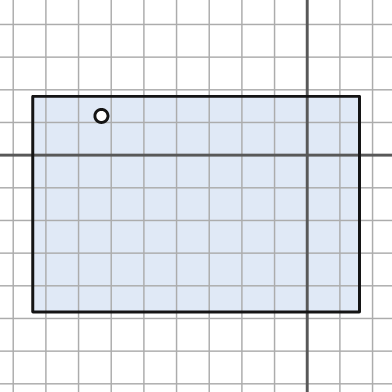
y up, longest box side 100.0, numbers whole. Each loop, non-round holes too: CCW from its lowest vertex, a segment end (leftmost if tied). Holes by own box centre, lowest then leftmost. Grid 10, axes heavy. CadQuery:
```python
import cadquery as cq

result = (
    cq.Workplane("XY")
    .moveTo(-84.0, -48.0)
    .lineTo(16.0, -48.0)
    .lineTo(16.0, 18.0)
    .lineTo(-84.0, 18.0)
    .close()
    .moveTo(-63.0, 12.0)
    .circle(2.0)
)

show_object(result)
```